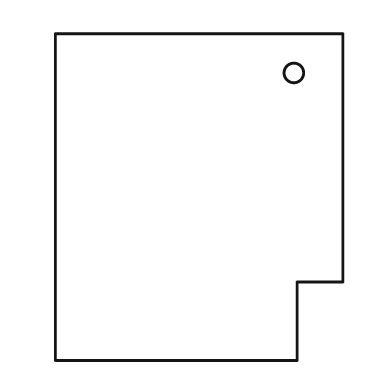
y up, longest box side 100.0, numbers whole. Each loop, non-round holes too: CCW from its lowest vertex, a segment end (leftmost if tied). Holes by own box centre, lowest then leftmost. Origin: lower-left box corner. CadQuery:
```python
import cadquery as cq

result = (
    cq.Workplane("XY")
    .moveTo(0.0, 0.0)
    .lineTo(74.0, 0.0)
    .lineTo(74.0, 24.0)
    .lineTo(88.0, 24.0)
    .lineTo(88.0, 100.0)
    .lineTo(0.0, 100.0)
    .close()
    .moveTo(73.0, 88.0)
    .circle(3.0)
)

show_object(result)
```